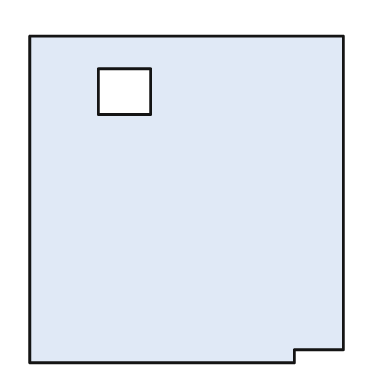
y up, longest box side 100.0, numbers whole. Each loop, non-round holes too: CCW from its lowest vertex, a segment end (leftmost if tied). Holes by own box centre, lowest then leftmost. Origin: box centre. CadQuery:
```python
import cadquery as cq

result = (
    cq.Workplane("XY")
    .moveTo(-48.0, -50.0)
    .lineTo(33.0, -50.0)
    .lineTo(33.0, -46.0)
    .lineTo(48.0, -46.0)
    .lineTo(48.0, 50.0)
    .lineTo(-48.0, 50.0)
    .close()
    .moveTo(-27.0, 26.0)
    .lineTo(-11.0, 26.0)
    .lineTo(-11.0, 40.0)
    .lineTo(-27.0, 40.0)
    .close()
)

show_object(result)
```